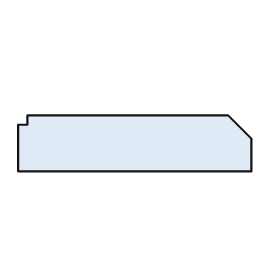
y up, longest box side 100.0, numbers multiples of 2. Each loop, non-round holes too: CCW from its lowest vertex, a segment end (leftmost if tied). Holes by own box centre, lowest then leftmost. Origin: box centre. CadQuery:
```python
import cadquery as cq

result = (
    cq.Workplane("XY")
    .moveTo(-50.0, -12.0)
    .lineTo(50.0, -12.0)
    .lineTo(50.0, 2.0)
    .lineTo(40.0, 12.0)
    .lineTo(-46.0, 12.0)
    .lineTo(-46.0, 8.0)
    .lineTo(-50.0, 8.0)
    .close()
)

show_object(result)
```